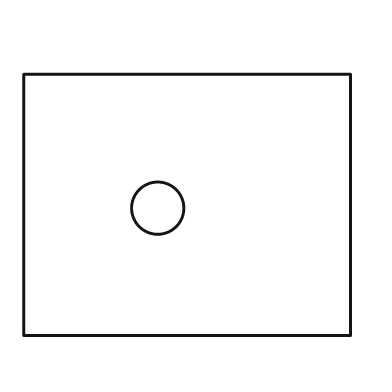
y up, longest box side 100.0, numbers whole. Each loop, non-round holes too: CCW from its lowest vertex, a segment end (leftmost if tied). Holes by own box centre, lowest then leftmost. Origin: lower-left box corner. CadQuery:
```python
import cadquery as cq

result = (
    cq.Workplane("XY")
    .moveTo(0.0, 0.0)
    .lineTo(100.0, 0.0)
    .lineTo(100.0, 80.0)
    .lineTo(0.0, 80.0)
    .close()
    .moveTo(41.0, 39.0)
    .circle(8.0)
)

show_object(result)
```